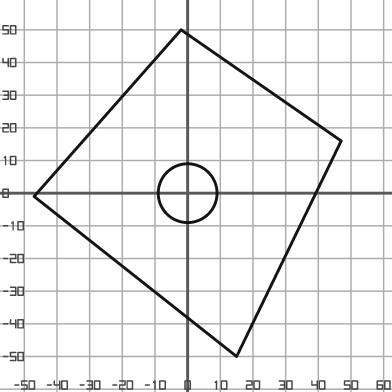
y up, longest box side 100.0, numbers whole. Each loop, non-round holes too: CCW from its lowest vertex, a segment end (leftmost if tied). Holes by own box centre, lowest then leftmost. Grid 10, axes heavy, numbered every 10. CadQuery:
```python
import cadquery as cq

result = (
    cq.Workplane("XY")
    .moveTo(15.0, -50.0)
    .lineTo(47.0, 16.0)
    .lineTo(-2.0, 50.0)
    .lineTo(-47.0, -1.0)
    .close()
    .moveTo(0.0, 0.0)
    .circle(9.0)
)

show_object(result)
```